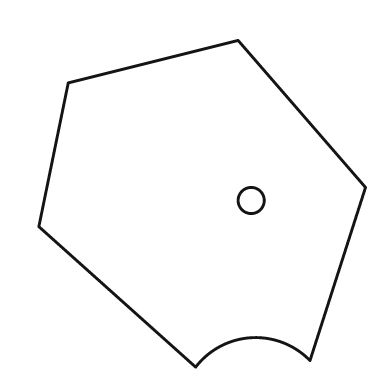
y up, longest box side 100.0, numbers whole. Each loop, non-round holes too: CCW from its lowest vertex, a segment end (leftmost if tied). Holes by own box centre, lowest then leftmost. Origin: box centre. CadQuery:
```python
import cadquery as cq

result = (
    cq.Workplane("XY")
    .moveTo(-2.0, -50.0)
    .threePointArc((15.0, -41.0), (33.0, -48.0))
    .lineTo(50.0, 5.0)
    .lineTo(11.0, 50.0)
    .lineTo(-41.0, 37.0)
    .lineTo(-50.0, -7.0)
    .close()
    .moveTo(15.0, 1.0)
    .circle(4.0)
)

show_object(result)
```